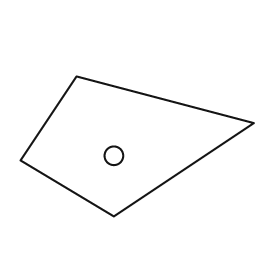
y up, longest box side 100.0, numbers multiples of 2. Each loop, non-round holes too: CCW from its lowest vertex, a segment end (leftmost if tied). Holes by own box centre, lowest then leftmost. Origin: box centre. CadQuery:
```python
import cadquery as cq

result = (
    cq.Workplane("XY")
    .moveTo(-10.0, -30.0)
    .lineTo(50.0, 10.0)
    .lineTo(-26.0, 30.0)
    .lineTo(-50.0, -6.0)
    .close()
    .moveTo(-10.0, -4.0)
    .circle(4.0)
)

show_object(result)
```